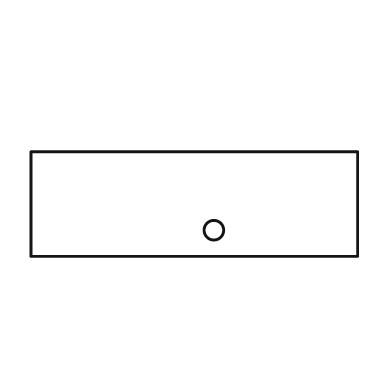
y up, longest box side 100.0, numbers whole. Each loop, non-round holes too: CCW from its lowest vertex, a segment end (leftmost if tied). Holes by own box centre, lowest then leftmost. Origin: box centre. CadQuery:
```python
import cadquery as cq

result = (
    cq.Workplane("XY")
    .moveTo(-50.0, -16.0)
    .lineTo(50.0, -16.0)
    .lineTo(50.0, 16.0)
    .lineTo(-50.0, 16.0)
    .close()
    .moveTo(6.0, -8.0)
    .circle(3.0)
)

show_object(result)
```